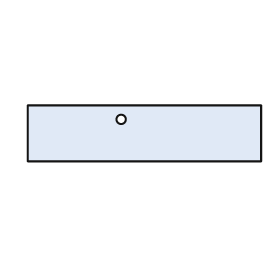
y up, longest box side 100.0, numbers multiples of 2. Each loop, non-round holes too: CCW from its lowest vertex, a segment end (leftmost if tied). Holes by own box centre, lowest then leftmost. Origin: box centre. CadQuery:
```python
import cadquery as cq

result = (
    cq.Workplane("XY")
    .moveTo(-50.0, -12.0)
    .lineTo(50.0, -12.0)
    .lineTo(50.0, 12.0)
    .lineTo(-50.0, 12.0)
    .close()
    .moveTo(-10.0, 6.0)
    .circle(2.0)
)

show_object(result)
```